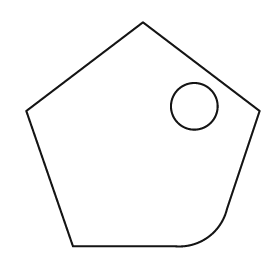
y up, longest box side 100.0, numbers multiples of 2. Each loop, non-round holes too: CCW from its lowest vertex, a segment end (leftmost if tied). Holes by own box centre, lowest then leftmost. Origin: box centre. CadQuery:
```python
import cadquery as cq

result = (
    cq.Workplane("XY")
    .moveTo(-30.0, -48.0)
    .lineTo(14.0, -48.0)
    .threePointArc((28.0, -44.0), (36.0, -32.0))
    .lineTo(50.0, 10.0)
    .lineTo(0.0, 48.0)
    .lineTo(-50.0, 10.0)
    .close()
    .moveTo(22.0, 12.0)
    .circle(10.0)
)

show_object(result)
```